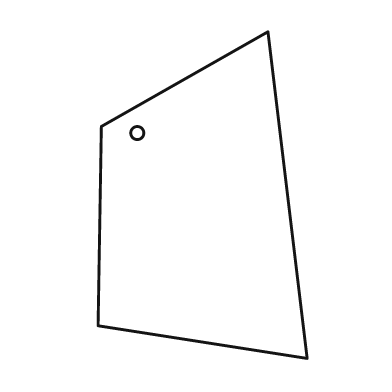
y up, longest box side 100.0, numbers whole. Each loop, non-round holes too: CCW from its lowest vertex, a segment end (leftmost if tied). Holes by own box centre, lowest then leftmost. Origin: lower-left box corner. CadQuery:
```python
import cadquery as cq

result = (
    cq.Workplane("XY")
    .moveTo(64.0, 0.0)
    .lineTo(52.0, 100.0)
    .lineTo(1.0, 71.0)
    .lineTo(0.0, 10.0)
    .close()
    .moveTo(12.0, 69.0)
    .circle(2.0)
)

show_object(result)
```